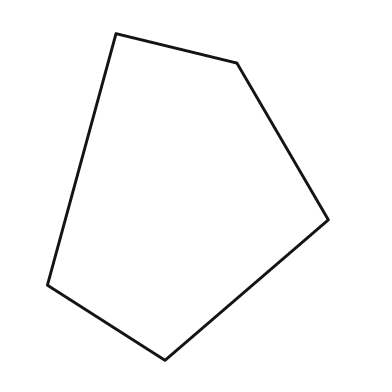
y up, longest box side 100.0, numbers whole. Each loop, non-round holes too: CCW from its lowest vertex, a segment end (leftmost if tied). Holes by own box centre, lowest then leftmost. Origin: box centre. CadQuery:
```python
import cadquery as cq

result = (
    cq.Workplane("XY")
    .moveTo(-7.0, -50.0)
    .lineTo(43.0, -7.0)
    .lineTo(15.0, 41.0)
    .lineTo(-22.0, 50.0)
    .lineTo(-43.0, -27.0)
    .close()
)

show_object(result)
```